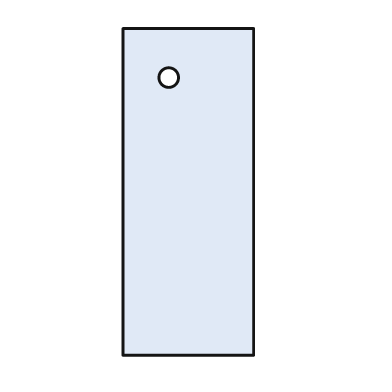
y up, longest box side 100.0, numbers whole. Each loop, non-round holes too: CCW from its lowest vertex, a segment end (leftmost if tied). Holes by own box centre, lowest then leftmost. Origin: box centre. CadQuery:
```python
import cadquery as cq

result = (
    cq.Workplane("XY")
    .moveTo(-20.0, -50.0)
    .lineTo(20.0, -50.0)
    .lineTo(20.0, 50.0)
    .lineTo(-20.0, 50.0)
    .close()
    .moveTo(-6.0, 35.0)
    .circle(3.0)
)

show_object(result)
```